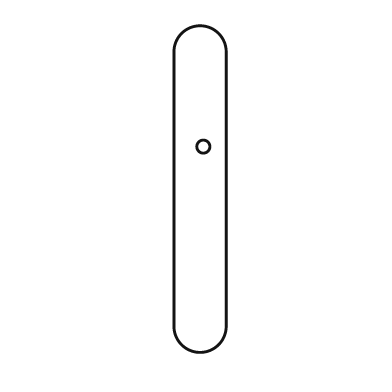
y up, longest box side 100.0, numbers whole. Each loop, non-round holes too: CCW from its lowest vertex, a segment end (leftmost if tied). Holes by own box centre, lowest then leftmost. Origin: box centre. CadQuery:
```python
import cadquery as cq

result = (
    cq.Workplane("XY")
    .moveTo(-8.0, -42.0)
    .threePointArc((0.0, -50.0), (8.0, -42.0))
    .lineTo(8.0, 42.0)
    .threePointArc((0.0, 50.0), (-8.0, 42.0))
    .close()
    .moveTo(1.0, 13.0)
    .circle(2.0)
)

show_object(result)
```